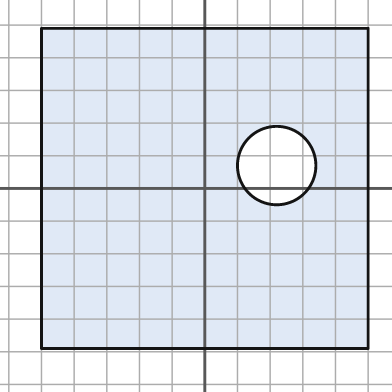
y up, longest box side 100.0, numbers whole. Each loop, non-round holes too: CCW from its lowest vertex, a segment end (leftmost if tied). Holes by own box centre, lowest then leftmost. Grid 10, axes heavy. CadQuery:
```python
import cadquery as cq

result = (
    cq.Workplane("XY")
    .moveTo(-50.0, -49.0)
    .lineTo(50.0, -49.0)
    .lineTo(50.0, 49.0)
    .lineTo(-50.0, 49.0)
    .close()
    .moveTo(22.0, 7.0)
    .circle(12.0)
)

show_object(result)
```